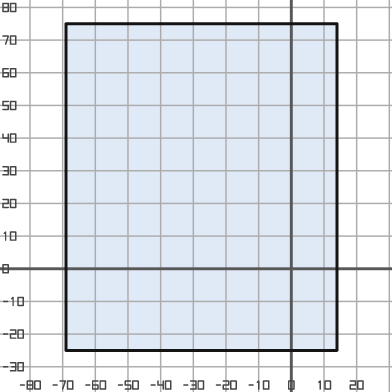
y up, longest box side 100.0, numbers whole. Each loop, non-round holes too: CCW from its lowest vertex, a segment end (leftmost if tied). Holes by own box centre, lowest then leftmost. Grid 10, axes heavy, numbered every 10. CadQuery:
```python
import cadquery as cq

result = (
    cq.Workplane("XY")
    .moveTo(-69.0, -25.0)
    .lineTo(14.0, -25.0)
    .lineTo(14.0, 75.0)
    .lineTo(-69.0, 75.0)
    .close()
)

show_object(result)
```